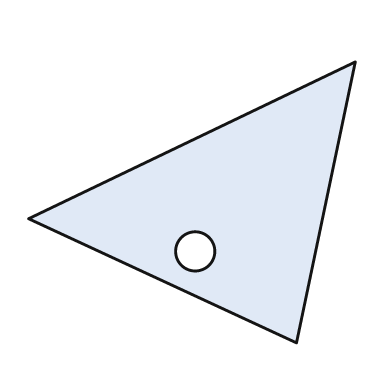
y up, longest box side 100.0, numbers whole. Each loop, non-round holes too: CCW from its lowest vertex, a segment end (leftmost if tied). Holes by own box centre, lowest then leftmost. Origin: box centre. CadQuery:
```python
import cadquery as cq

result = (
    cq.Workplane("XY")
    .moveTo(32.0, -43.0)
    .lineTo(50.0, 43.0)
    .lineTo(-50.0, -5.0)
    .close()
    .moveTo(1.0, -15.0)
    .circle(6.0)
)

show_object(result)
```